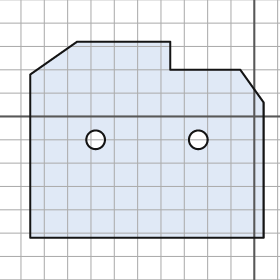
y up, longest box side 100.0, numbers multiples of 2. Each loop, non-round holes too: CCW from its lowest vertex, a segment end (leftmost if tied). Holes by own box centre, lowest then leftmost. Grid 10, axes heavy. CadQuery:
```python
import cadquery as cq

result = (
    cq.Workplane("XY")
    .moveTo(-96.0, -52.0)
    .lineTo(4.0, -52.0)
    .lineTo(4.0, 6.0)
    .lineTo(-6.0, 20.0)
    .lineTo(-36.0, 20.0)
    .lineTo(-36.0, 32.0)
    .lineTo(-76.0, 32.0)
    .lineTo(-96.0, 18.0)
    .close()
    .moveTo(-68.0, -10.0)
    .circle(4.0)
    .moveTo(-24.0, -10.0)
    .circle(4.0)
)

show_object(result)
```